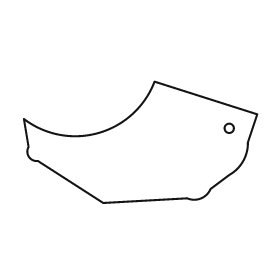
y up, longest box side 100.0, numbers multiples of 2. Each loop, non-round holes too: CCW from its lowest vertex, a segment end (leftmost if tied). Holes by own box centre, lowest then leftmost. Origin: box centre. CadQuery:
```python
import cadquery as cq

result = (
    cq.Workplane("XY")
    .moveTo(-16.0, -26.0)
    .lineTo(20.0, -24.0)
    .threePointArc((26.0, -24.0), (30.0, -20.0))
    .lineTo(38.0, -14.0)
    .threePointArc((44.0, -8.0), (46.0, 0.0))
    .lineTo(50.0, 12.0)
    .lineTo(6.0, 26.0)
    .threePointArc((-18.0, 4.0), (-50.0, 10.0))
    .lineTo(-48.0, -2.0)
    .threePointArc((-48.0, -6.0), (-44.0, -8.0))
    .close()
    .moveTo(38.0, 6.0)
    .circle(2.0)
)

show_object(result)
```